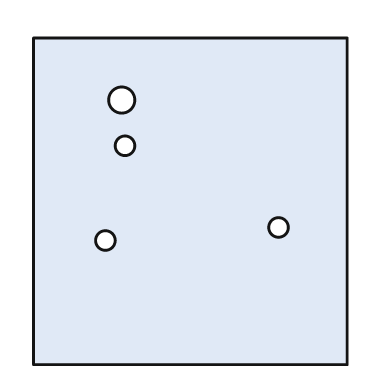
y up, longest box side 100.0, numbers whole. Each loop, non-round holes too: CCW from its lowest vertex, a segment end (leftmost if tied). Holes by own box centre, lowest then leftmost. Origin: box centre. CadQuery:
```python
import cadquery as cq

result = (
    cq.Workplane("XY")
    .moveTo(-48.0, -50.0)
    .lineTo(48.0, -50.0)
    .lineTo(48.0, 50.0)
    .lineTo(-48.0, 50.0)
    .close()
    .moveTo(-26.0, -12.0)
    .circle(3.0)
    .moveTo(27.0, -8.0)
    .circle(3.0)
    .moveTo(-20.0, 17.0)
    .circle(3.0)
    .moveTo(-21.0, 31.0)
    .circle(4.0)
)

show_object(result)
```